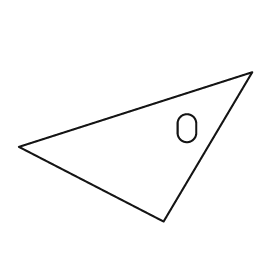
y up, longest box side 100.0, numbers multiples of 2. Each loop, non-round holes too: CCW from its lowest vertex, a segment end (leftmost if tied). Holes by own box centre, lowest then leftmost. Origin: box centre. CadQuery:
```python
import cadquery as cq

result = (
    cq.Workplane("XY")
    .moveTo(12.0, -32.0)
    .lineTo(50.0, 32.0)
    .lineTo(-50.0, 0.0)
    .close()
    .moveTo(18.0, 6.0)
    .threePointArc((22.0, 2.0), (26.0, 6.0))
    .lineTo(26.0, 10.0)
    .threePointArc((22.0, 14.0), (18.0, 10.0))
    .close()
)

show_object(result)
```